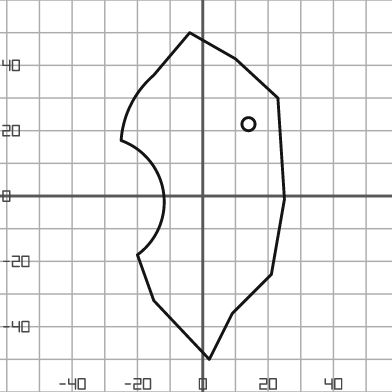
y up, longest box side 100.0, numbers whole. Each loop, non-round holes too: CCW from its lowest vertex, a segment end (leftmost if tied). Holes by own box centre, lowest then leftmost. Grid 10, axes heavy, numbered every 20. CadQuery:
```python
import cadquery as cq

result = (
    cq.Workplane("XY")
    .moveTo(2.0, -50.0)
    .lineTo(9.0, -36.0)
    .lineTo(21.0, -24.0)
    .lineTo(25.0, -1.0)
    .lineTo(23.0, 30.0)
    .lineTo(10.0, 42.0)
    .lineTo(-4.0, 50.0)
    .lineTo(-15.0, 37.0)
    .threePointArc((-22.0, 28.0), (-25.0, 17.0))
    .threePointArc((-12.0, 1.0), (-20.0, -18.0))
    .lineTo(-15.0, -32.0)
    .close()
    .moveTo(14.0, 22.0)
    .circle(2.0)
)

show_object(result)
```